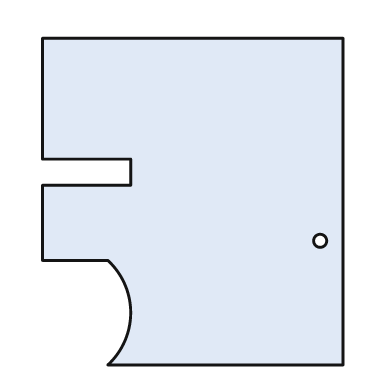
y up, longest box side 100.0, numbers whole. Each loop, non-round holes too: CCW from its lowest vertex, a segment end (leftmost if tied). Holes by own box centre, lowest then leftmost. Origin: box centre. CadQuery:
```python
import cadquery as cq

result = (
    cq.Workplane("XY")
    .moveTo(-26.0, -50.0)
    .lineTo(46.0, -50.0)
    .lineTo(46.0, 50.0)
    .lineTo(-46.0, 50.0)
    .lineTo(-46.0, 13.0)
    .lineTo(-19.0, 13.0)
    .lineTo(-19.0, 5.0)
    .lineTo(-46.0, 5.0)
    .lineTo(-46.0, -18.0)
    .lineTo(-26.0, -18.0)
    .threePointArc((-19.0, -34.0), (-26.0, -50.0))
    .close()
    .moveTo(39.0, -12.0)
    .circle(2.0)
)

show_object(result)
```